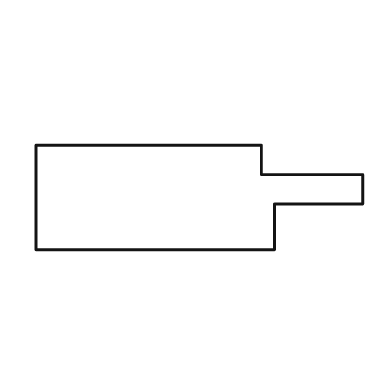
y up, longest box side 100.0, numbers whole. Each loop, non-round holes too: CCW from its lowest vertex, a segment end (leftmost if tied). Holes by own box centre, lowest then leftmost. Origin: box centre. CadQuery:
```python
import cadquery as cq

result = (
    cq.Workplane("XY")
    .moveTo(-50.0, -16.0)
    .lineTo(23.0, -16.0)
    .lineTo(23.0, -2.0)
    .lineTo(50.0, -2.0)
    .lineTo(50.0, 7.0)
    .lineTo(19.0, 7.0)
    .lineTo(19.0, 16.0)
    .lineTo(-50.0, 16.0)
    .close()
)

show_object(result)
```